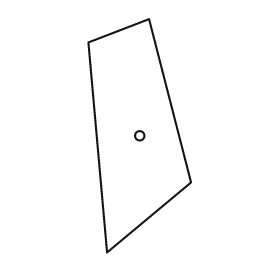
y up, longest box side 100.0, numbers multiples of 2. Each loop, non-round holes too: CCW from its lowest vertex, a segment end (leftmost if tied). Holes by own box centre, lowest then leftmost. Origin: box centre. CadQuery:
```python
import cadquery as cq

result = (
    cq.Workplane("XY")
    .moveTo(-14.0, -50.0)
    .lineTo(22.0, -20.0)
    .lineTo(4.0, 50.0)
    .lineTo(-22.0, 40.0)
    .close()
    .moveTo(0.0, 0.0)
    .circle(2.0)
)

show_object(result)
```